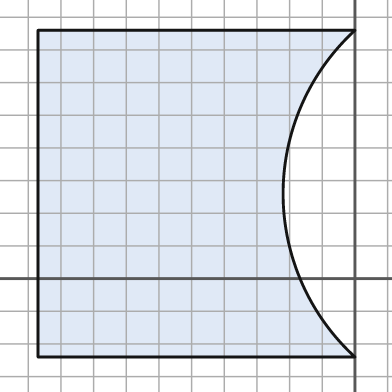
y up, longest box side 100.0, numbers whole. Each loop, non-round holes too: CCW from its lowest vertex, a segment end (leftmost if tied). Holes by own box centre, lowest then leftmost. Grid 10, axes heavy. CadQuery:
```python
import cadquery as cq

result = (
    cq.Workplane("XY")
    .moveTo(-97.0, -24.0)
    .lineTo(0.0, -24.0)
    .threePointArc((-22.0, 26.0), (0.0, 76.0))
    .lineTo(-97.0, 76.0)
    .close()
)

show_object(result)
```